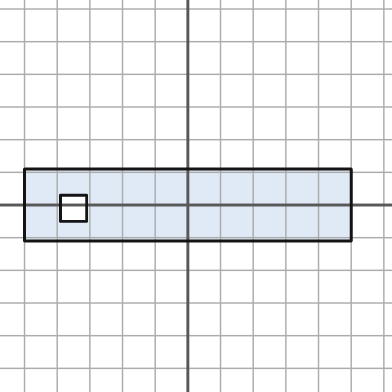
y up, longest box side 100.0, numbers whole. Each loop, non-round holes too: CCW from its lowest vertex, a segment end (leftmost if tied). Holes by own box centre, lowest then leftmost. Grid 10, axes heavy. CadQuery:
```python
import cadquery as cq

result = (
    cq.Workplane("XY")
    .moveTo(-50.0, -11.0)
    .lineTo(50.0, -11.0)
    .lineTo(50.0, 11.0)
    .lineTo(-50.0, 11.0)
    .close()
    .moveTo(-39.0, -5.0)
    .lineTo(-31.0, -5.0)
    .lineTo(-31.0, 3.0)
    .lineTo(-39.0, 3.0)
    .close()
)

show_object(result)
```